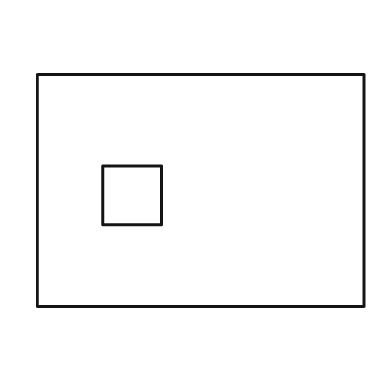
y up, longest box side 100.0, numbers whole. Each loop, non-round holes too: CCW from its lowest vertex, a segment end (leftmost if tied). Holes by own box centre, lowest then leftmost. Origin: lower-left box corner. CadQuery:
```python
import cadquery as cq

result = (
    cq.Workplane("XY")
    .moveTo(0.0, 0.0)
    .lineTo(100.0, 0.0)
    .lineTo(100.0, 71.0)
    .lineTo(0.0, 71.0)
    .close()
    .moveTo(20.0, 25.0)
    .lineTo(38.0, 25.0)
    .lineTo(38.0, 43.0)
    .lineTo(20.0, 43.0)
    .close()
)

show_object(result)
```